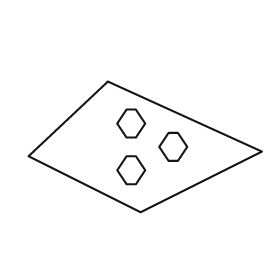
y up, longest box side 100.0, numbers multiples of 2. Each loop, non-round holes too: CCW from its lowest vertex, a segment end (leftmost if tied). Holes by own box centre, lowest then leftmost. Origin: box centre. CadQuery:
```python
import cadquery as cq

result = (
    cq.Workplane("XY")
    .moveTo(-2.0, -28.0)
    .lineTo(50.0, -2.0)
    .lineTo(-16.0, 28.0)
    .lineTo(-50.0, -4.0)
    .close()
    .moveTo(-8.0, -16.0)
    .lineTo(-4.0, -16.0)
    .lineTo(0.0, -10.0)
    .lineTo(-4.0, -4.0)
    .lineTo(-8.0, -4.0)
    .lineTo(-12.0, -10.0)
    .close()
    .moveTo(10.0, -6.0)
    .lineTo(14.0, -6.0)
    .lineTo(18.0, 0.0)
    .lineTo(14.0, 6.0)
    .lineTo(10.0, 6.0)
    .lineTo(6.0, 0.0)
    .close()
    .moveTo(-8.0, 4.0)
    .lineTo(-4.0, 4.0)
    .lineTo(0.0, 10.0)
    .lineTo(-4.0, 16.0)
    .lineTo(-8.0, 16.0)
    .lineTo(-12.0, 10.0)
    .close()
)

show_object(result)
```